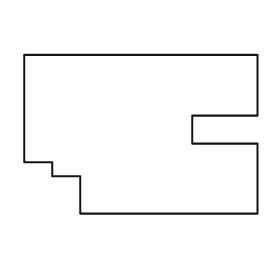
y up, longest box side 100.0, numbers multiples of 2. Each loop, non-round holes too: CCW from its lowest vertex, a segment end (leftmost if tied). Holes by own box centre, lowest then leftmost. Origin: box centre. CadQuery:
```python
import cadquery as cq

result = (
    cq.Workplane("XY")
    .moveTo(-26.0, -34.0)
    .lineTo(50.0, -34.0)
    .lineTo(50.0, -4.0)
    .lineTo(22.0, -4.0)
    .lineTo(22.0, 8.0)
    .lineTo(50.0, 8.0)
    .lineTo(50.0, 34.0)
    .lineTo(-50.0, 34.0)
    .lineTo(-50.0, -12.0)
    .lineTo(-38.0, -12.0)
    .lineTo(-38.0, -18.0)
    .lineTo(-26.0, -18.0)
    .close()
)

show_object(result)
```